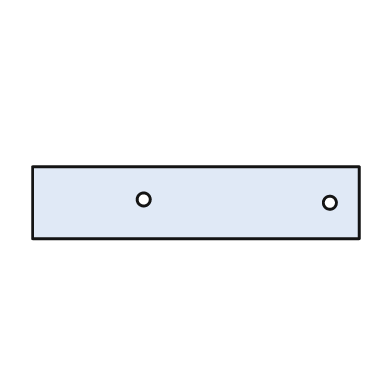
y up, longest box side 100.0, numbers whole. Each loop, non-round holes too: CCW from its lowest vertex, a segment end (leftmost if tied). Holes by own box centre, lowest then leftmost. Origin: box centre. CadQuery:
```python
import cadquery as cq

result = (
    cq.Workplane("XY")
    .moveTo(-50.0, -11.0)
    .lineTo(50.0, -11.0)
    .lineTo(50.0, 11.0)
    .lineTo(-50.0, 11.0)
    .close()
    .moveTo(41.0, 0.0)
    .circle(2.0)
    .moveTo(-16.0, 1.0)
    .circle(2.0)
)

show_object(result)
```